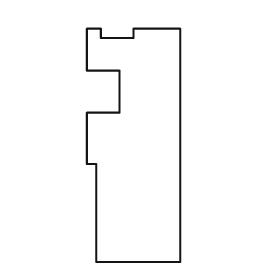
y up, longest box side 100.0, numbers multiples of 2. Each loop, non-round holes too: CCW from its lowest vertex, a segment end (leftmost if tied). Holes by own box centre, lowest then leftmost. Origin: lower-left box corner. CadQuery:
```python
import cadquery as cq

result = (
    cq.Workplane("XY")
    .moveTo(4.0, 0.0)
    .lineTo(40.0, 0.0)
    .lineTo(40.0, 100.0)
    .lineTo(20.0, 100.0)
    .lineTo(20.0, 96.0)
    .lineTo(6.0, 96.0)
    .lineTo(6.0, 100.0)
    .lineTo(0.0, 100.0)
    .lineTo(0.0, 82.0)
    .lineTo(14.0, 82.0)
    .lineTo(14.0, 64.0)
    .lineTo(0.0, 64.0)
    .lineTo(0.0, 42.0)
    .lineTo(4.0, 42.0)
    .close()
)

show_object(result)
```